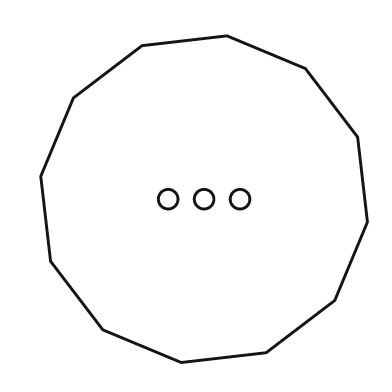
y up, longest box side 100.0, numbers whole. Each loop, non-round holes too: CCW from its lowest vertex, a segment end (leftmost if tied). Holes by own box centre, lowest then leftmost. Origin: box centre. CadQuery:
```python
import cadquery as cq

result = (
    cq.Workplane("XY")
    .moveTo(-7.0, -50.0)
    .lineTo(19.0, -47.0)
    .lineTo(40.0, -31.0)
    .lineTo(50.0, -7.0)
    .lineTo(47.0, 19.0)
    .lineTo(31.0, 40.0)
    .lineTo(7.0, 50.0)
    .lineTo(-19.0, 47.0)
    .lineTo(-40.0, 31.0)
    .lineTo(-50.0, 7.0)
    .lineTo(-47.0, -19.0)
    .lineTo(-31.0, -40.0)
    .close()
    .moveTo(-11.0, 0.0)
    .circle(3.0)
    .moveTo(0.0, 0.0)
    .circle(3.0)
    .moveTo(11.0, 0.0)
    .circle(3.0)
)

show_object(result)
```